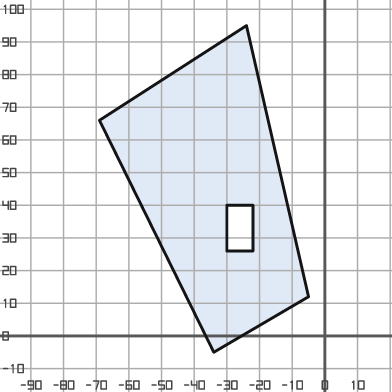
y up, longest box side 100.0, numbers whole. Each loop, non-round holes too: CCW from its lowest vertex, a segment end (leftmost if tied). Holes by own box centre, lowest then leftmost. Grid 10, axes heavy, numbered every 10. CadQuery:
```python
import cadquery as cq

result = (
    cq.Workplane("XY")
    .moveTo(-34.0, -5.0)
    .lineTo(-5.0, 12.0)
    .lineTo(-24.0, 95.0)
    .lineTo(-69.0, 66.0)
    .close()
    .moveTo(-30.0, 26.0)
    .lineTo(-22.0, 26.0)
    .lineTo(-22.0, 40.0)
    .lineTo(-30.0, 40.0)
    .close()
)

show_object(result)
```